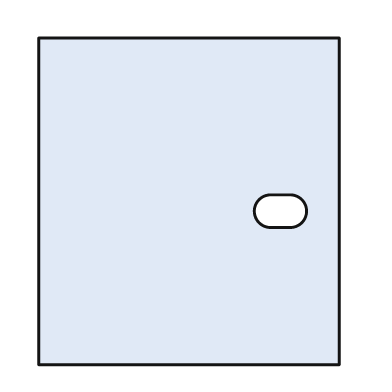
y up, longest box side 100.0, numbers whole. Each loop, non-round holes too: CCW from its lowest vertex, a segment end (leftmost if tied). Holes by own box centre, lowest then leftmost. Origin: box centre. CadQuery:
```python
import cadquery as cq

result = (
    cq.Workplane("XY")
    .moveTo(-46.0, -50.0)
    .lineTo(46.0, -50.0)
    .lineTo(46.0, 50.0)
    .lineTo(-46.0, 50.0)
    .close()
    .moveTo(25.0, -8.0)
    .lineTo(31.0, -8.0)
    .threePointArc((36.0, -3.0), (31.0, 2.0))
    .lineTo(25.0, 2.0)
    .threePointArc((20.0, -3.0), (25.0, -8.0))
    .close()
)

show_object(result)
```